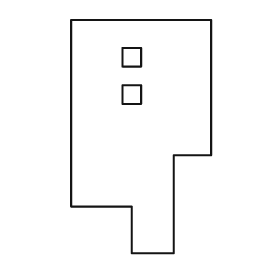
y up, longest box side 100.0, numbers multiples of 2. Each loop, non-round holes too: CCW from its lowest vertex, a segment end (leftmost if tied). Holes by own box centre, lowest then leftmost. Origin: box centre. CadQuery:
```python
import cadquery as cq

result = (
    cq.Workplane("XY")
    .moveTo(-4.0, -50.0)
    .lineTo(14.0, -50.0)
    .lineTo(14.0, -8.0)
    .lineTo(30.0, -8.0)
    .lineTo(30.0, 50.0)
    .lineTo(-30.0, 50.0)
    .lineTo(-30.0, -30.0)
    .lineTo(-4.0, -30.0)
    .close()
    .moveTo(-8.0, 14.0)
    .lineTo(0.0, 14.0)
    .lineTo(0.0, 22.0)
    .lineTo(-8.0, 22.0)
    .close()
    .moveTo(-8.0, 30.0)
    .lineTo(0.0, 30.0)
    .lineTo(0.0, 38.0)
    .lineTo(-8.0, 38.0)
    .close()
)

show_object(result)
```